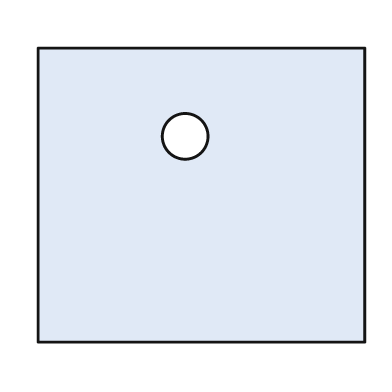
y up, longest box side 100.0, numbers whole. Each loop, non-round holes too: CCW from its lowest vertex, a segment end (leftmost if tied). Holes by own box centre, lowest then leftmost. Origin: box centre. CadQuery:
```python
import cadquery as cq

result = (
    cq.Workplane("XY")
    .moveTo(-50.0, -45.0)
    .lineTo(50.0, -45.0)
    .lineTo(50.0, 45.0)
    .lineTo(-50.0, 45.0)
    .close()
    .moveTo(-5.0, 18.0)
    .circle(7.0)
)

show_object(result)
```